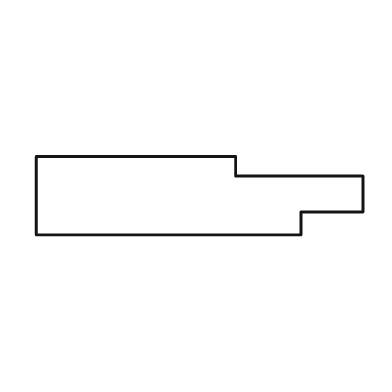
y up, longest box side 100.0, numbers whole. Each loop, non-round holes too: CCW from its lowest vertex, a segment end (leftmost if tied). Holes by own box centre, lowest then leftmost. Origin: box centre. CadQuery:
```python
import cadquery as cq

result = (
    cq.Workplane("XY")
    .moveTo(-50.0, -12.0)
    .lineTo(31.0, -12.0)
    .lineTo(31.0, -5.0)
    .lineTo(50.0, -5.0)
    .lineTo(50.0, 6.0)
    .lineTo(11.0, 6.0)
    .lineTo(11.0, 12.0)
    .lineTo(-50.0, 12.0)
    .close()
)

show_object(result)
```